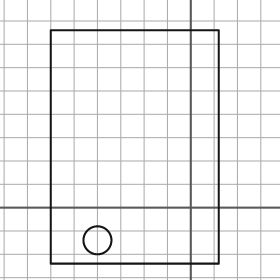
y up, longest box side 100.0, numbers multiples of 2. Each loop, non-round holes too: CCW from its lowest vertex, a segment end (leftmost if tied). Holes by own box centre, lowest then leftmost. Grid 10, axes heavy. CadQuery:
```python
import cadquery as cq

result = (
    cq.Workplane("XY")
    .moveTo(-60.0, -24.0)
    .lineTo(12.0, -24.0)
    .lineTo(12.0, 76.0)
    .lineTo(-60.0, 76.0)
    .close()
    .moveTo(-40.0, -14.0)
    .circle(6.0)
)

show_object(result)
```